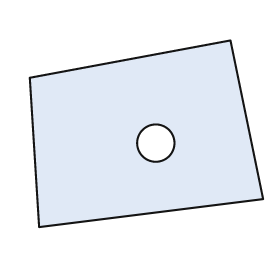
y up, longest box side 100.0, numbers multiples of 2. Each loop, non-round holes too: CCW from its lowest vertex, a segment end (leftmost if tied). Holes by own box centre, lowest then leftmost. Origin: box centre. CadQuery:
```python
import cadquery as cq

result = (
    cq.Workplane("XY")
    .moveTo(-46.0, -40.0)
    .lineTo(50.0, -28.0)
    .lineTo(36.0, 40.0)
    .lineTo(-50.0, 24.0)
    .close()
    .moveTo(4.0, -4.0)
    .circle(8.0)
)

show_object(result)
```